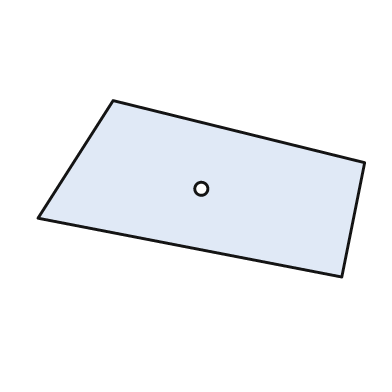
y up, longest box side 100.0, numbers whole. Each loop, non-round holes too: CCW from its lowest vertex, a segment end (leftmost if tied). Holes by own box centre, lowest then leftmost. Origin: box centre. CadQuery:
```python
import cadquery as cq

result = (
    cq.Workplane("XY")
    .moveTo(43.0, -27.0)
    .lineTo(50.0, 8.0)
    .lineTo(-27.0, 27.0)
    .lineTo(-50.0, -9.0)
    .close()
    .moveTo(0.0, 0.0)
    .circle(2.0)
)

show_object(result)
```